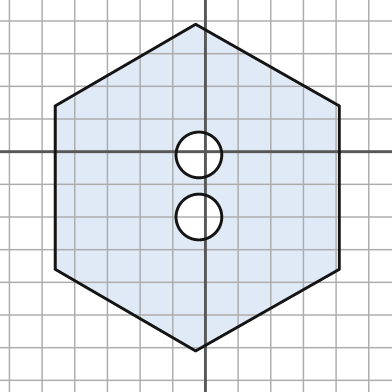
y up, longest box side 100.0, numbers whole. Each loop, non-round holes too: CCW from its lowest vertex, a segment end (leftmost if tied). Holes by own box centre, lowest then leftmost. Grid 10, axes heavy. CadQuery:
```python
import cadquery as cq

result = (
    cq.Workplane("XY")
    .moveTo(-3.0, -61.0)
    .lineTo(41.0, -36.0)
    .lineTo(41.0, 14.0)
    .lineTo(-3.0, 39.0)
    .lineTo(-46.0, 14.0)
    .lineTo(-46.0, -36.0)
    .close()
    .moveTo(-2.0, -20.0)
    .circle(7.0)
    .moveTo(-2.0, -1.0)
    .circle(7.0)
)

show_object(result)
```